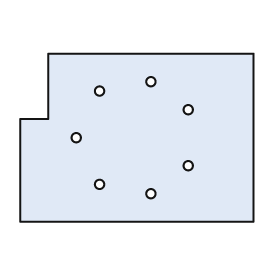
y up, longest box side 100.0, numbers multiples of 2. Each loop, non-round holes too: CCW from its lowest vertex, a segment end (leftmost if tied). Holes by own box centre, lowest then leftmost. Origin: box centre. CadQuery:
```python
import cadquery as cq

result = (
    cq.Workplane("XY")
    .moveTo(-50.0, -36.0)
    .lineTo(50.0, -36.0)
    .lineTo(50.0, 36.0)
    .lineTo(-38.0, 36.0)
    .lineTo(-38.0, 8.0)
    .lineTo(-50.0, 8.0)
    .close()
    .moveTo(6.0, -24.0)
    .circle(2.0)
    .moveTo(-16.0, -20.0)
    .circle(2.0)
    .moveTo(22.0, -12.0)
    .circle(2.0)
    .moveTo(-26.0, 0.0)
    .circle(2.0)
    .moveTo(22.0, 12.0)
    .circle(2.0)
    .moveTo(-16.0, 20.0)
    .circle(2.0)
    .moveTo(6.0, 24.0)
    .circle(2.0)
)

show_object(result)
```